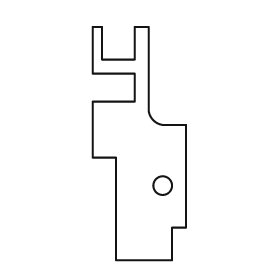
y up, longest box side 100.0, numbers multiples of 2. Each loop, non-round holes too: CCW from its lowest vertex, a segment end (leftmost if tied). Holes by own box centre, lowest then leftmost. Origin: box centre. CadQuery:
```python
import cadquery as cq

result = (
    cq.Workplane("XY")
    .moveTo(-10.0, -50.0)
    .lineTo(14.0, -50.0)
    .lineTo(14.0, -36.0)
    .lineTo(20.0, -36.0)
    .lineTo(20.0, 8.0)
    .lineTo(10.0, 8.0)
    .threePointArc((6.0, 10.0), (4.0, 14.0))
    .lineTo(4.0, 50.0)
    .lineTo(-2.0, 50.0)
    .lineTo(-2.0, 36.0)
    .lineTo(-16.0, 36.0)
    .lineTo(-16.0, 50.0)
    .lineTo(-20.0, 50.0)
    .lineTo(-20.0, 30.0)
    .lineTo(-2.0, 30.0)
    .lineTo(-2.0, 18.0)
    .lineTo(-20.0, 18.0)
    .lineTo(-20.0, -6.0)
    .lineTo(-10.0, -6.0)
    .close()
    .moveTo(10.0, -18.0)
    .circle(4.0)
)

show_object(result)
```